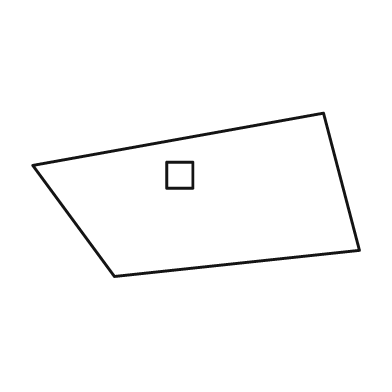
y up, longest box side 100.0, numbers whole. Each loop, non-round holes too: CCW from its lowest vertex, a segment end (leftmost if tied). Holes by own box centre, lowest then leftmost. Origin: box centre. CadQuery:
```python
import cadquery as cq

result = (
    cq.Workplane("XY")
    .moveTo(-25.0, -25.0)
    .lineTo(50.0, -17.0)
    .lineTo(39.0, 25.0)
    .lineTo(-50.0, 9.0)
    .close()
    .moveTo(-9.0, 2.0)
    .lineTo(-1.0, 2.0)
    .lineTo(-1.0, 10.0)
    .lineTo(-9.0, 10.0)
    .close()
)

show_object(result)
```